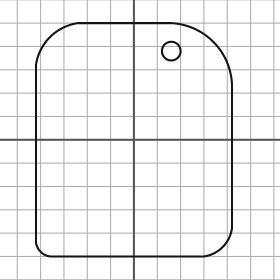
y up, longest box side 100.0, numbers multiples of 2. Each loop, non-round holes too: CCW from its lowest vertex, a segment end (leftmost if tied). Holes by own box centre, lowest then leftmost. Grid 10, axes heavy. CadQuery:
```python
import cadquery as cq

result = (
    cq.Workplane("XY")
    .moveTo(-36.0, -50.0)
    .lineTo(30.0, -50.0)
    .threePointArc((38.0, -46.0), (42.0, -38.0))
    .lineTo(42.0, 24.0)
    .threePointArc((34.0, 42.0), (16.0, 50.0))
    .lineTo(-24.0, 50.0)
    .threePointArc((-36.0, 44.0), (-42.0, 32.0))
    .lineTo(-42.0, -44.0)
    .threePointArc((-40.0, -48.0), (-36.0, -50.0))
    .close()
    .moveTo(16.0, 38.0)
    .circle(4.0)
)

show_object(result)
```